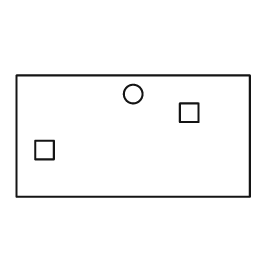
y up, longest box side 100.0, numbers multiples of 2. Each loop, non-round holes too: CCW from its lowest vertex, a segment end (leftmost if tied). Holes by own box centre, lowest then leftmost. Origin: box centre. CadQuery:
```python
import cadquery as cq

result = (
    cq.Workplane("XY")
    .moveTo(-50.0, -26.0)
    .lineTo(50.0, -26.0)
    .lineTo(50.0, 26.0)
    .lineTo(-50.0, 26.0)
    .close()
    .moveTo(-42.0, -10.0)
    .lineTo(-34.0, -10.0)
    .lineTo(-34.0, -2.0)
    .lineTo(-42.0, -2.0)
    .close()
    .moveTo(20.0, 6.0)
    .lineTo(28.0, 6.0)
    .lineTo(28.0, 14.0)
    .lineTo(20.0, 14.0)
    .close()
    .moveTo(0.0, 18.0)
    .circle(4.0)
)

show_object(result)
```